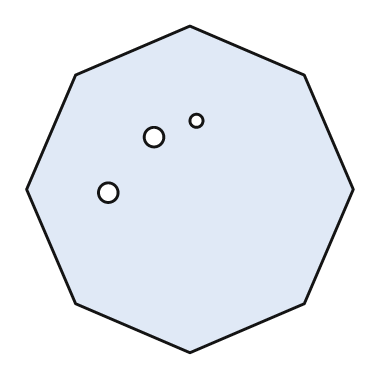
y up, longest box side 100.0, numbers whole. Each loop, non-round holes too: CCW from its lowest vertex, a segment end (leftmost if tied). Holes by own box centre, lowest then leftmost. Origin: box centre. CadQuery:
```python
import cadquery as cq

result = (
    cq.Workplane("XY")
    .moveTo(0.0, -50.0)
    .lineTo(35.0, -35.0)
    .lineTo(50.0, 0.0)
    .lineTo(35.0, 35.0)
    .lineTo(0.0, 50.0)
    .lineTo(-35.0, 35.0)
    .lineTo(-50.0, 0.0)
    .lineTo(-35.0, -35.0)
    .close()
    .moveTo(-25.0, -1.0)
    .circle(3.0)
    .moveTo(-11.0, 16.0)
    .circle(3.0)
    .moveTo(2.0, 21.0)
    .circle(2.0)
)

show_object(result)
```